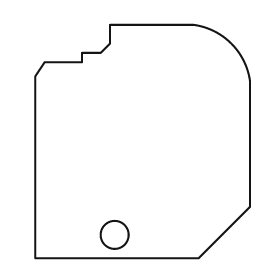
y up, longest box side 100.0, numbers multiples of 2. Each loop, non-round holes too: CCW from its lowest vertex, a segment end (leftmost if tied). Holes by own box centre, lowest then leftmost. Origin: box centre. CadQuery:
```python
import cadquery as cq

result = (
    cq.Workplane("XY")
    .moveTo(-46.0, -50.0)
    .lineTo(24.0, -50.0)
    .lineTo(46.0, -28.0)
    .lineTo(46.0, 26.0)
    .threePointArc((38.0, 42.0), (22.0, 50.0))
    .lineTo(-14.0, 50.0)
    .lineTo(-14.0, 42.0)
    .lineTo(-18.0, 38.0)
    .lineTo(-26.0, 38.0)
    .lineTo(-26.0, 34.0)
    .lineTo(-42.0, 34.0)
    .lineTo(-46.0, 28.0)
    .close()
    .moveTo(-12.0, -40.0)
    .circle(6.0)
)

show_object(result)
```